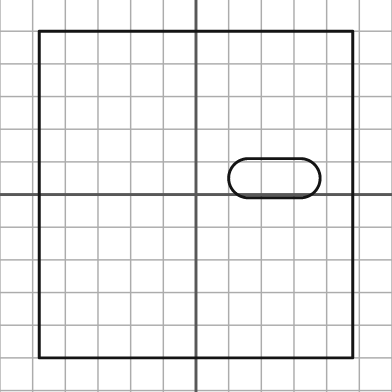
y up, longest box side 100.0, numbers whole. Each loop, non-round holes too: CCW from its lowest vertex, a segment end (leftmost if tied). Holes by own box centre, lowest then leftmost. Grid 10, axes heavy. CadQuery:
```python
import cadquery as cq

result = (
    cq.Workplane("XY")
    .moveTo(-48.0, -50.0)
    .lineTo(48.0, -50.0)
    .lineTo(48.0, 50.0)
    .lineTo(-48.0, 50.0)
    .close()
    .moveTo(16.0, -1.0)
    .lineTo(32.0, -1.0)
    .threePointArc((38.0, 5.0), (32.0, 11.0))
    .lineTo(16.0, 11.0)
    .threePointArc((10.0, 5.0), (16.0, -1.0))
    .close()
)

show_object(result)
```